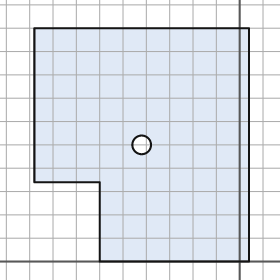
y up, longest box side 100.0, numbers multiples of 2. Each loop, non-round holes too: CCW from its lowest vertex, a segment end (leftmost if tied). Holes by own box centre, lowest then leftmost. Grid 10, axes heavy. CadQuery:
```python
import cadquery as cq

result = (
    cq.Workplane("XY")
    .moveTo(-60.0, 0.0)
    .lineTo(4.0, 0.0)
    .lineTo(4.0, 100.0)
    .lineTo(-88.0, 100.0)
    .lineTo(-88.0, 34.0)
    .lineTo(-60.0, 34.0)
    .close()
    .moveTo(-42.0, 50.0)
    .circle(4.0)
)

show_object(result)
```